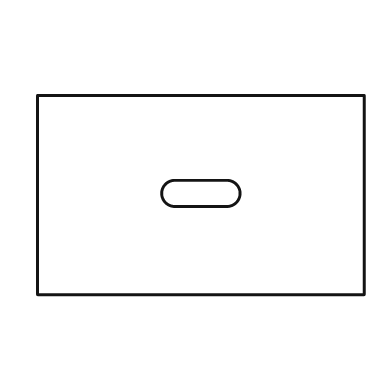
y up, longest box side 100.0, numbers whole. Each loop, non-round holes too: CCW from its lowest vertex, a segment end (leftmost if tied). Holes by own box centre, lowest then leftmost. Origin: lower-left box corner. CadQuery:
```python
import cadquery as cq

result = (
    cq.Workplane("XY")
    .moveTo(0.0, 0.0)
    .lineTo(100.0, 0.0)
    .lineTo(100.0, 61.0)
    .lineTo(0.0, 61.0)
    .close()
    .moveTo(42.0, 27.0)
    .lineTo(58.0, 27.0)
    .threePointArc((62.0, 31.0), (58.0, 35.0))
    .lineTo(42.0, 35.0)
    .threePointArc((38.0, 31.0), (42.0, 27.0))
    .close()
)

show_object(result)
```